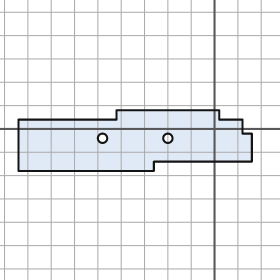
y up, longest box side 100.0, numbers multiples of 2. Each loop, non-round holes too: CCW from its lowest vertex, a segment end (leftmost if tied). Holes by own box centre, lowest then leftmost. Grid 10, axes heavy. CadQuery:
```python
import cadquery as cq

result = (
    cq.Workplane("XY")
    .moveTo(-84.0, -18.0)
    .lineTo(-26.0, -18.0)
    .lineTo(-26.0, -14.0)
    .lineTo(16.0, -14.0)
    .lineTo(16.0, -2.0)
    .lineTo(12.0, -2.0)
    .lineTo(12.0, 4.0)
    .lineTo(2.0, 4.0)
    .lineTo(2.0, 8.0)
    .lineTo(-42.0, 8.0)
    .lineTo(-42.0, 4.0)
    .lineTo(-84.0, 4.0)
    .close()
    .moveTo(-48.0, -4.0)
    .circle(2.0)
    .moveTo(-20.0, -4.0)
    .circle(2.0)
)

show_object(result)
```